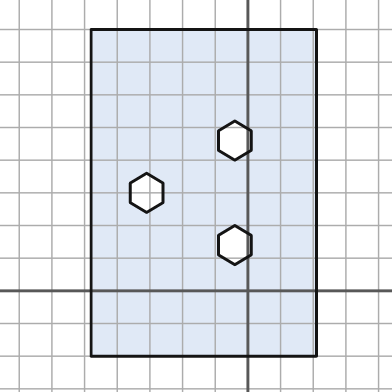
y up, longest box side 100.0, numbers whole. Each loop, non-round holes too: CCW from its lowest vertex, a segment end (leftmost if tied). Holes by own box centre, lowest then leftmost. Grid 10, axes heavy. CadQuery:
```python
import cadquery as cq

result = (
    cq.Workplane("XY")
    .moveTo(-48.0, -20.0)
    .lineTo(21.0, -20.0)
    .lineTo(21.0, 80.0)
    .lineTo(-48.0, 80.0)
    .close()
    .moveTo(-4.0, 8.0)
    .lineTo(1.0, 11.0)
    .lineTo(1.0, 17.0)
    .lineTo(-4.0, 20.0)
    .lineTo(-9.0, 17.0)
    .lineTo(-9.0, 11.0)
    .close()
    .moveTo(-31.0, 24.0)
    .lineTo(-26.0, 27.0)
    .lineTo(-26.0, 33.0)
    .lineTo(-31.0, 36.0)
    .lineTo(-36.0, 33.0)
    .lineTo(-36.0, 27.0)
    .close()
    .moveTo(-4.0, 40.0)
    .lineTo(1.0, 43.0)
    .lineTo(1.0, 49.0)
    .lineTo(-4.0, 52.0)
    .lineTo(-9.0, 49.0)
    .lineTo(-9.0, 43.0)
    .close()
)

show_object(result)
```